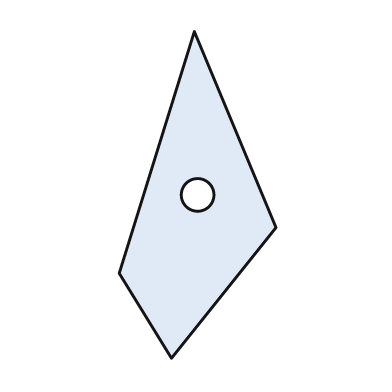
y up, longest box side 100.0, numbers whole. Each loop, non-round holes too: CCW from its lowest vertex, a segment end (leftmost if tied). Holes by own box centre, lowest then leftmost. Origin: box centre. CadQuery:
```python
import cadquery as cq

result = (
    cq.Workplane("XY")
    .moveTo(-8.0, -50.0)
    .lineTo(24.0, -10.0)
    .lineTo(-1.0, 50.0)
    .lineTo(-24.0, -24.0)
    .close()
    .moveTo(0.0, 0.0)
    .circle(5.0)
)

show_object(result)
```